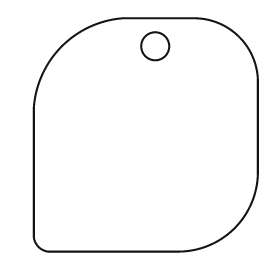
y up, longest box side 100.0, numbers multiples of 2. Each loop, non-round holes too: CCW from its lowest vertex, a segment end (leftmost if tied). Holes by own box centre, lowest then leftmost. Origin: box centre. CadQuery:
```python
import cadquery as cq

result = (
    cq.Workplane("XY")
    .moveTo(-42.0, -50.0)
    .lineTo(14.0, -50.0)
    .threePointArc((38.0, -40.0), (48.0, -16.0))
    .lineTo(48.0, 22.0)
    .threePointArc((40.0, 42.0), (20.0, 50.0))
    .lineTo(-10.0, 50.0)
    .threePointArc((-36.0, 38.0), (-48.0, 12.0))
    .lineTo(-48.0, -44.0)
    .threePointArc((-46.0, -48.0), (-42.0, -50.0))
    .close()
    .moveTo(4.0, 38.0)
    .circle(6.0)
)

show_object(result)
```